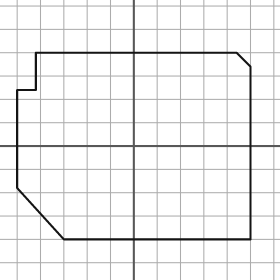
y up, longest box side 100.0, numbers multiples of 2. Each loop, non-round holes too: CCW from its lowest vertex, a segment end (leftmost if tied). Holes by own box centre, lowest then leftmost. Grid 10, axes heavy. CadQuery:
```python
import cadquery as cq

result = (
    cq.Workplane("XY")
    .moveTo(-30.0, -40.0)
    .lineTo(50.0, -40.0)
    .lineTo(50.0, 34.0)
    .lineTo(44.0, 40.0)
    .lineTo(-42.0, 40.0)
    .lineTo(-42.0, 24.0)
    .lineTo(-50.0, 24.0)
    .lineTo(-50.0, -18.0)
    .close()
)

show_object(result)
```